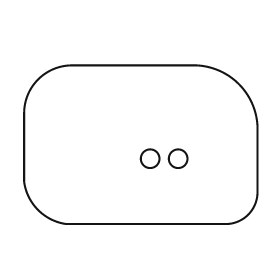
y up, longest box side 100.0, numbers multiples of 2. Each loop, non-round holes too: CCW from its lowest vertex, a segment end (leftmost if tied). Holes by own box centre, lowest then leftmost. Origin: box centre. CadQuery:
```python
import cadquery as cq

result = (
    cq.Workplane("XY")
    .moveTo(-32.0, -34.0)
    .lineTo(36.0, -34.0)
    .threePointArc((46.0, -30.0), (50.0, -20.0))
    .lineTo(50.0, 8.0)
    .threePointArc((42.0, 26.0), (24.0, 34.0))
    .lineTo(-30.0, 34.0)
    .threePointArc((-44.0, 28.0), (-50.0, 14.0))
    .lineTo(-50.0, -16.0)
    .threePointArc((-44.0, -28.0), (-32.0, -34.0))
    .close()
    .moveTo(4.0, -6.0)
    .circle(4.0)
    .moveTo(16.0, -6.0)
    .circle(4.0)
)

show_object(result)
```